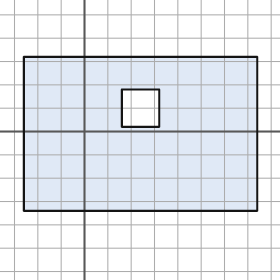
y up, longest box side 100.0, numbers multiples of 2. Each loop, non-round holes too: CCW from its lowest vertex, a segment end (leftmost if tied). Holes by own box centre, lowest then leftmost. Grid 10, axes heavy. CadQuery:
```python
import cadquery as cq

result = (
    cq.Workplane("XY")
    .moveTo(-26.0, -34.0)
    .lineTo(74.0, -34.0)
    .lineTo(74.0, 32.0)
    .lineTo(-26.0, 32.0)
    .close()
    .moveTo(16.0, 2.0)
    .lineTo(32.0, 2.0)
    .lineTo(32.0, 18.0)
    .lineTo(16.0, 18.0)
    .close()
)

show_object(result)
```